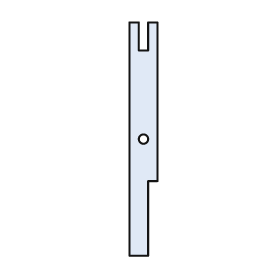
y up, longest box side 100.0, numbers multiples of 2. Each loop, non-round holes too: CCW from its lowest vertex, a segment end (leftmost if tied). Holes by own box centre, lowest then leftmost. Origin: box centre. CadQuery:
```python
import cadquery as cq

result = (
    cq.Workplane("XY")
    .moveTo(-6.0, -50.0)
    .lineTo(2.0, -50.0)
    .lineTo(2.0, -18.0)
    .lineTo(6.0, -18.0)
    .lineTo(6.0, 50.0)
    .lineTo(2.0, 50.0)
    .lineTo(2.0, 38.0)
    .lineTo(-2.0, 38.0)
    .lineTo(-2.0, 50.0)
    .lineTo(-6.0, 50.0)
    .close()
    .moveTo(0.0, 0.0)
    .circle(2.0)
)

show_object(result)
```